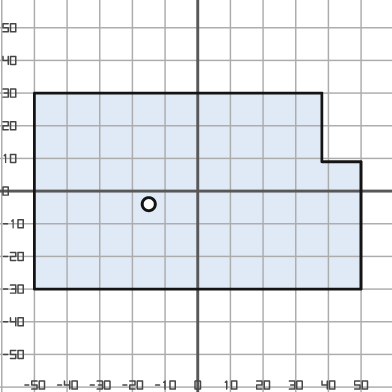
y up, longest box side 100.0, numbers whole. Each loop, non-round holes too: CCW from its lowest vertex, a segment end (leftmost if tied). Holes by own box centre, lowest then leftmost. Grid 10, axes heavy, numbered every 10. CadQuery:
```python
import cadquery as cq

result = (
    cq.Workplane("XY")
    .moveTo(-50.0, -30.0)
    .lineTo(50.0, -30.0)
    .lineTo(50.0, 9.0)
    .lineTo(38.0, 9.0)
    .lineTo(38.0, 30.0)
    .lineTo(-50.0, 30.0)
    .close()
    .moveTo(-15.0, -4.0)
    .circle(2.0)
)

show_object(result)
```